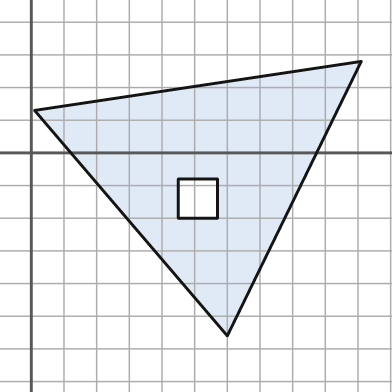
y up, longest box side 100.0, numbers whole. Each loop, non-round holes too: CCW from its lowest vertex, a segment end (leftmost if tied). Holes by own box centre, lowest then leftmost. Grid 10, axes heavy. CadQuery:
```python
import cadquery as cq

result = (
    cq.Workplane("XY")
    .moveTo(60.0, -56.0)
    .lineTo(101.0, 28.0)
    .lineTo(1.0, 13.0)
    .close()
    .moveTo(45.0, -20.0)
    .lineTo(57.0, -20.0)
    .lineTo(57.0, -8.0)
    .lineTo(45.0, -8.0)
    .close()
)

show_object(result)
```